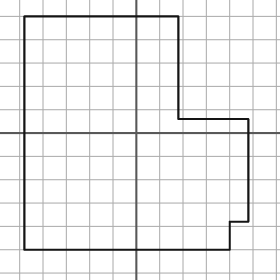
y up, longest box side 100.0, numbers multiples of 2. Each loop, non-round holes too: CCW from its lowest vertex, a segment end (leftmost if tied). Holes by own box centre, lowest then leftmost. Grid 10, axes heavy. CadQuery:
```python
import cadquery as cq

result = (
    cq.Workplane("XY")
    .moveTo(-48.0, -50.0)
    .lineTo(40.0, -50.0)
    .lineTo(40.0, -38.0)
    .lineTo(48.0, -38.0)
    .lineTo(48.0, 6.0)
    .lineTo(18.0, 6.0)
    .lineTo(18.0, 50.0)
    .lineTo(-48.0, 50.0)
    .close()
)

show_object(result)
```